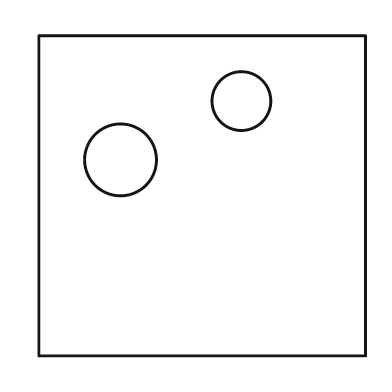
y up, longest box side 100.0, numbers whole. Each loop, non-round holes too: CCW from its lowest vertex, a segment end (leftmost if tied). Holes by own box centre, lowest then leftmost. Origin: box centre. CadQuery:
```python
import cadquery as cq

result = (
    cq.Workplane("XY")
    .moveTo(-50.0, -49.0)
    .lineTo(50.0, -49.0)
    .lineTo(50.0, 49.0)
    .lineTo(-50.0, 49.0)
    .close()
    .moveTo(-25.0, 11.0)
    .circle(11.0)
    .moveTo(12.0, 29.0)
    .circle(9.0)
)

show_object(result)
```